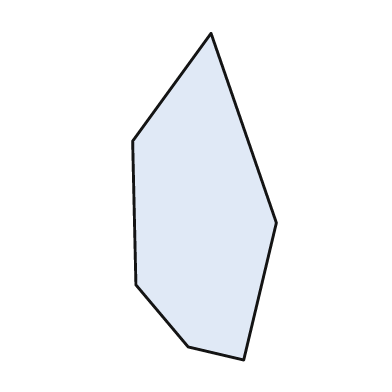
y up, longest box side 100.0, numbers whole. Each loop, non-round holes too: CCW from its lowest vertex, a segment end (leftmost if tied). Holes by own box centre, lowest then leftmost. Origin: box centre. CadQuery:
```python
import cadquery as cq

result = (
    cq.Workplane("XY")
    .moveTo(12.0, -50.0)
    .lineTo(22.0, -8.0)
    .lineTo(2.0, 50.0)
    .lineTo(-22.0, 17.0)
    .lineTo(-21.0, -27.0)
    .lineTo(-5.0, -46.0)
    .close()
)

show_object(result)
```